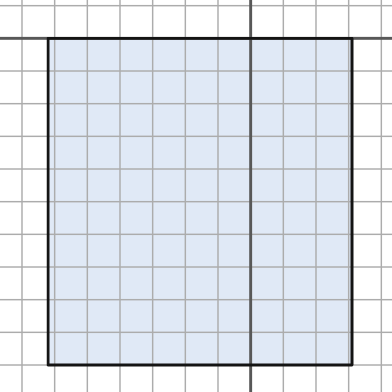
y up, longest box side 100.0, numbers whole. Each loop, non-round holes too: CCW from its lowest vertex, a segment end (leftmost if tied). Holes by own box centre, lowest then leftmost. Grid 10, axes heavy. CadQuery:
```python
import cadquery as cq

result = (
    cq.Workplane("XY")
    .moveTo(-62.0, -100.0)
    .lineTo(31.0, -100.0)
    .lineTo(31.0, 0.0)
    .lineTo(-62.0, 0.0)
    .close()
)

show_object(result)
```